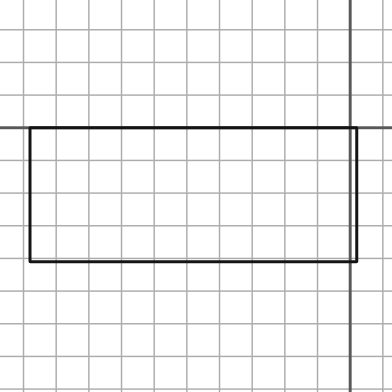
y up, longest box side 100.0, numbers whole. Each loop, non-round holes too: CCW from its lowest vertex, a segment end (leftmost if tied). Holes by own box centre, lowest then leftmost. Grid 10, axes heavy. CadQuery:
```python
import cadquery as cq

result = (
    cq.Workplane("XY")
    .moveTo(-98.0, -41.0)
    .lineTo(2.0, -41.0)
    .lineTo(2.0, 0.0)
    .lineTo(-98.0, 0.0)
    .close()
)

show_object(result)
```